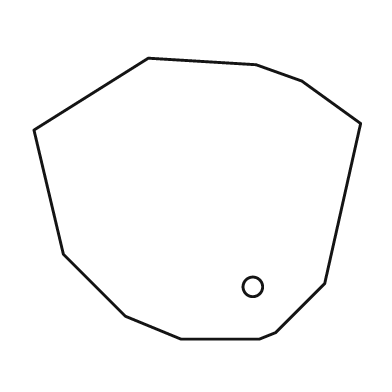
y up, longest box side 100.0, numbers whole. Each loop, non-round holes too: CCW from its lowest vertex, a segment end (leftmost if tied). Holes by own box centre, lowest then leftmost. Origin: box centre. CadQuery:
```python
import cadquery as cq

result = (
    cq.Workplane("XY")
    .moveTo(-5.0, -43.0)
    .lineTo(19.0, -43.0)
    .lineTo(24.0, -41.0)
    .lineTo(39.0, -26.0)
    .lineTo(50.0, 23.0)
    .lineTo(32.0, 36.0)
    .lineTo(18.0, 41.0)
    .lineTo(-15.0, 43.0)
    .lineTo(-50.0, 21.0)
    .lineTo(-41.0, -17.0)
    .lineTo(-22.0, -36.0)
    .close()
    .moveTo(17.0, -27.0)
    .circle(3.0)
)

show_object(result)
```